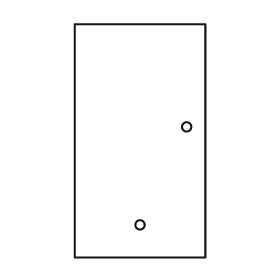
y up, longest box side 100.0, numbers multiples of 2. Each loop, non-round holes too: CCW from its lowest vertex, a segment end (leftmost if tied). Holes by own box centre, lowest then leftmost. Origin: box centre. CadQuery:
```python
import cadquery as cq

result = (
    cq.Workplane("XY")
    .moveTo(-28.0, -50.0)
    .lineTo(28.0, -50.0)
    .lineTo(28.0, 50.0)
    .lineTo(-28.0, 50.0)
    .close()
    .moveTo(0.0, -36.0)
    .circle(2.0)
    .moveTo(20.0, 6.0)
    .circle(2.0)
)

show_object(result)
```